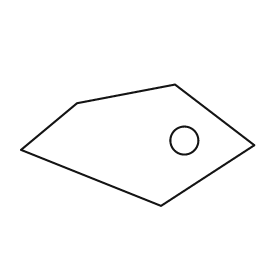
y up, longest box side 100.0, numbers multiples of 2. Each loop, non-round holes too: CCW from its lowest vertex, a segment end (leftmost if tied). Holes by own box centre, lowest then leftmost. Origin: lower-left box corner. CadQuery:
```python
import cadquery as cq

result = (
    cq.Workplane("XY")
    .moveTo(60.0, 0.0)
    .lineTo(100.0, 26.0)
    .lineTo(66.0, 52.0)
    .lineTo(24.0, 44.0)
    .lineTo(0.0, 24.0)
    .close()
    .moveTo(70.0, 28.0)
    .circle(6.0)
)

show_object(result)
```